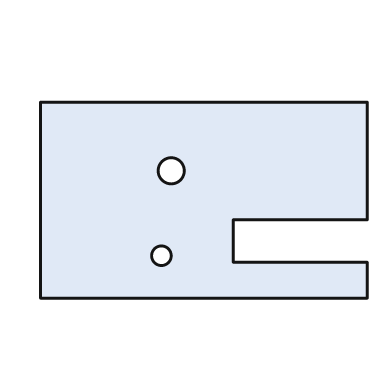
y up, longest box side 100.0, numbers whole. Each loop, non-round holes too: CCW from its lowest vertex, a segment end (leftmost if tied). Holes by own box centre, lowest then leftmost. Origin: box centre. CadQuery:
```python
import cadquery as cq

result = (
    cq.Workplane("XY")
    .moveTo(-50.0, -30.0)
    .lineTo(50.0, -30.0)
    .lineTo(50.0, -19.0)
    .lineTo(9.0, -19.0)
    .lineTo(9.0, -6.0)
    .lineTo(50.0, -6.0)
    .lineTo(50.0, 30.0)
    .lineTo(-50.0, 30.0)
    .close()
    .moveTo(-13.0, -17.0)
    .circle(3.0)
    .moveTo(-10.0, 9.0)
    .circle(4.0)
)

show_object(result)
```